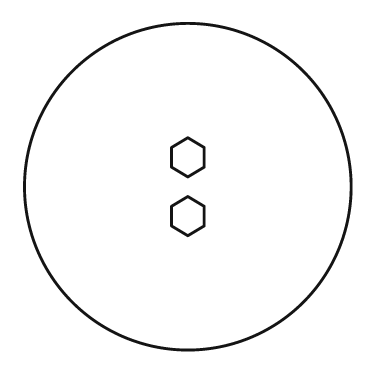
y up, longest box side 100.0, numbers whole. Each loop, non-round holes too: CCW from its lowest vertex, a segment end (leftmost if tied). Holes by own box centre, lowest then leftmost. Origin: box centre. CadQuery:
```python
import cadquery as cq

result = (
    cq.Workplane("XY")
    .moveTo(0.0, 0.0)
    .circle(50.0)
    .moveTo(0.0, -15.0)
    .lineTo(5.0, -12.0)
    .lineTo(5.0, -6.0)
    .lineTo(0.0, -3.0)
    .lineTo(-5.0, -6.0)
    .lineTo(-5.0, -12.0)
    .close()
    .moveTo(0.0, 3.0)
    .lineTo(5.0, 6.0)
    .lineTo(5.0, 12.0)
    .lineTo(0.0, 15.0)
    .lineTo(-5.0, 12.0)
    .lineTo(-5.0, 6.0)
    .close()
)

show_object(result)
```